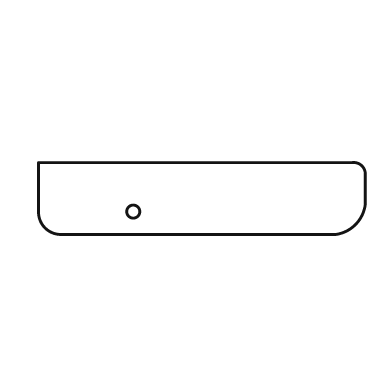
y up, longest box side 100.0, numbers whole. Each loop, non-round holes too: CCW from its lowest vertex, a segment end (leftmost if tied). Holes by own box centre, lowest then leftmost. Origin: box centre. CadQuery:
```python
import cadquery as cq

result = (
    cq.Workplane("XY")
    .moveTo(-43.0, -11.0)
    .lineTo(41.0, -11.0)
    .threePointArc((47.0, -8.0), (50.0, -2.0))
    .lineTo(50.0, 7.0)
    .threePointArc((49.0, 10.0), (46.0, 11.0))
    .lineTo(-50.0, 11.0)
    .lineTo(-50.0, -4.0)
    .threePointArc((-48.0, -9.0), (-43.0, -11.0))
    .close()
    .moveTo(-21.0, -4.0)
    .circle(2.0)
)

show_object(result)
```